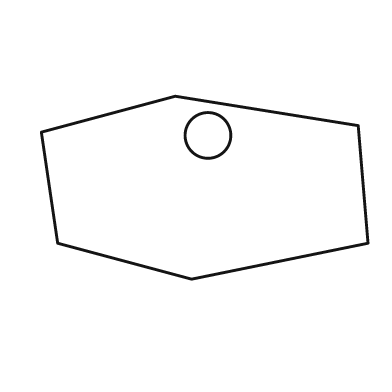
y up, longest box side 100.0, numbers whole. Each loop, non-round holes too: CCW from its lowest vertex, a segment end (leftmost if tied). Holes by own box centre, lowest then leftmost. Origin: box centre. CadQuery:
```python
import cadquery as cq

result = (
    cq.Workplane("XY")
    .moveTo(-4.0, -28.0)
    .lineTo(50.0, -17.0)
    .lineTo(47.0, 19.0)
    .lineTo(-9.0, 28.0)
    .lineTo(-50.0, 17.0)
    .lineTo(-45.0, -17.0)
    .close()
    .moveTo(1.0, 16.0)
    .circle(7.0)
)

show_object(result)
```